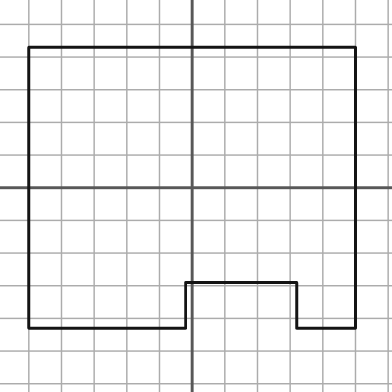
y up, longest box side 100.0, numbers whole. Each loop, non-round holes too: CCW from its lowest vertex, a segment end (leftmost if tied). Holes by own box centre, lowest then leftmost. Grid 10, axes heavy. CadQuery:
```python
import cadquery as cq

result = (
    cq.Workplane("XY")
    .moveTo(-50.0, -43.0)
    .lineTo(-2.0, -43.0)
    .lineTo(-2.0, -29.0)
    .lineTo(32.0, -29.0)
    .lineTo(32.0, -43.0)
    .lineTo(50.0, -43.0)
    .lineTo(50.0, 43.0)
    .lineTo(-50.0, 43.0)
    .close()
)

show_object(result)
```